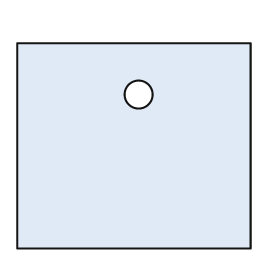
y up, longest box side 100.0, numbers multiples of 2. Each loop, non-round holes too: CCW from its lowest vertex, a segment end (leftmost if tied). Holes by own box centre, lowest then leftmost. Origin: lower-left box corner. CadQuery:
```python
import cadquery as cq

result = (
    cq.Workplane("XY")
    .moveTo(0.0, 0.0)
    .lineTo(100.0, 0.0)
    .lineTo(100.0, 88.0)
    .lineTo(0.0, 88.0)
    .close()
    .moveTo(52.0, 66.0)
    .circle(6.0)
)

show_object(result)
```